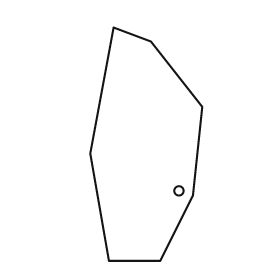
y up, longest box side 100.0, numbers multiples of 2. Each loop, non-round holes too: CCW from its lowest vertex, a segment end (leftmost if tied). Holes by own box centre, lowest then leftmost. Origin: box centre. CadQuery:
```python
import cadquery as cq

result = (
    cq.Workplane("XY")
    .moveTo(-16.0, -50.0)
    .lineTo(6.0, -50.0)
    .lineTo(20.0, -22.0)
    .lineTo(24.0, 16.0)
    .lineTo(2.0, 44.0)
    .lineTo(-14.0, 50.0)
    .lineTo(-24.0, -4.0)
    .close()
    .moveTo(14.0, -20.0)
    .circle(2.0)
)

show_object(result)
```